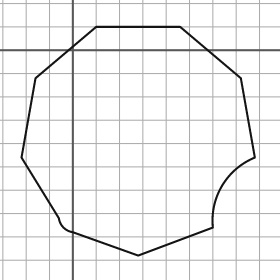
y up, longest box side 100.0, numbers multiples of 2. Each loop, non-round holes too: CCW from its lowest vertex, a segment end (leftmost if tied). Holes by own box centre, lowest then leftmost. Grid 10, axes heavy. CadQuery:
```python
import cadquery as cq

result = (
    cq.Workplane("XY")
    .moveTo(28.0, -88.0)
    .lineTo(60.0, -76.0)
    .threePointArc((64.0, -58.0), (78.0, -46.0))
    .lineTo(72.0, -12.0)
    .lineTo(46.0, 10.0)
    .lineTo(10.0, 10.0)
    .lineTo(-16.0, -12.0)
    .lineTo(-22.0, -46.0)
    .lineTo(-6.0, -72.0)
    .threePointArc((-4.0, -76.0), (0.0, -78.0))
    .close()
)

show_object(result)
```